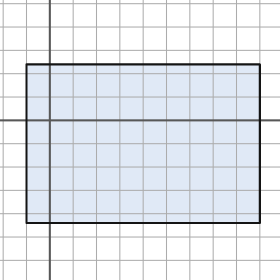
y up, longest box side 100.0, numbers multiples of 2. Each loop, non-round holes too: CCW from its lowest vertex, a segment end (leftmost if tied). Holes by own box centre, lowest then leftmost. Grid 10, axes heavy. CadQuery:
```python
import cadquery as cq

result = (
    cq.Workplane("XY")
    .moveTo(-10.0, -44.0)
    .lineTo(90.0, -44.0)
    .lineTo(90.0, 24.0)
    .lineTo(-10.0, 24.0)
    .close()
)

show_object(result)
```